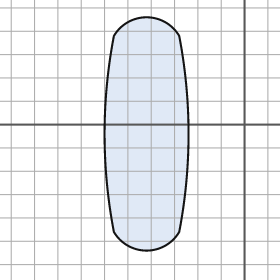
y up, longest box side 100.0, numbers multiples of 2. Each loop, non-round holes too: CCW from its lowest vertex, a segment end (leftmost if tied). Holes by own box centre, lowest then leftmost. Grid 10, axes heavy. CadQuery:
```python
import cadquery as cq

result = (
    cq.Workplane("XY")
    .moveTo(-56.0, -46.0)
    .threePointArc((-42.0, -54.0), (-28.0, -46.0))
    .threePointArc((-24.0, -4.0), (-28.0, 38.0))
    .threePointArc((-42.0, 46.0), (-56.0, 38.0))
    .threePointArc((-60.0, -4.0), (-56.0, -46.0))
    .close()
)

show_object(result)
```